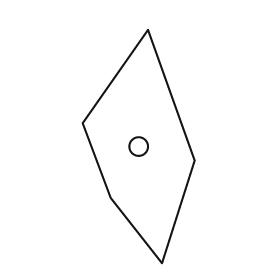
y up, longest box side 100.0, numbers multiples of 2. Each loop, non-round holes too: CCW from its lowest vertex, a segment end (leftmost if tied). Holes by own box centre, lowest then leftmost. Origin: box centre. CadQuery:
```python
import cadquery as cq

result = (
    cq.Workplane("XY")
    .moveTo(10.0, -50.0)
    .lineTo(24.0, -6.0)
    .lineTo(4.0, 50.0)
    .lineTo(-24.0, 10.0)
    .lineTo(-12.0, -22.0)
    .close()
    .moveTo(0.0, 0.0)
    .circle(4.0)
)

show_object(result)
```